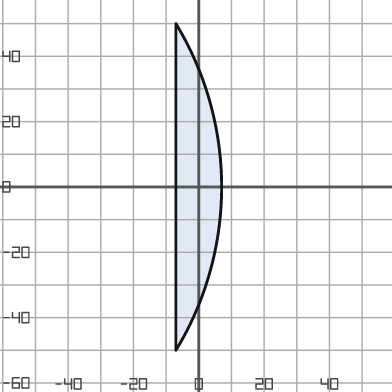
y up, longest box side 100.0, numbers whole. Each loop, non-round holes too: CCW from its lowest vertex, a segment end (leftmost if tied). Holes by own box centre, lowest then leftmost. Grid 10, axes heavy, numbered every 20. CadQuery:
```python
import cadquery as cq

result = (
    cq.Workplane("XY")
    .moveTo(-7.0, -50.0)
    .threePointArc((7.0, 0.0), (-7.0, 50.0))
    .close()
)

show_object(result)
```